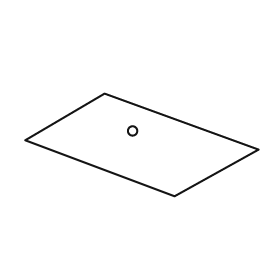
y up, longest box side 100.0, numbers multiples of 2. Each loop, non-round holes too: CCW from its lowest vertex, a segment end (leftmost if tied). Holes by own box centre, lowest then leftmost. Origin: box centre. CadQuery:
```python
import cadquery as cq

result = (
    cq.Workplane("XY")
    .moveTo(14.0, -22.0)
    .lineTo(50.0, -2.0)
    .lineTo(-16.0, 22.0)
    .lineTo(-50.0, 2.0)
    .close()
    .moveTo(-4.0, 6.0)
    .circle(2.0)
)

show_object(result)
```